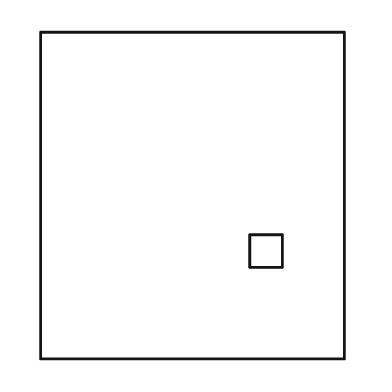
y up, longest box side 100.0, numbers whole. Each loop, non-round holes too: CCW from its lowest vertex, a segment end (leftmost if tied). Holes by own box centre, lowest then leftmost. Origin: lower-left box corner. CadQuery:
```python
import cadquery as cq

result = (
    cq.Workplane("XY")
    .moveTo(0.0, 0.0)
    .lineTo(93.0, 0.0)
    .lineTo(93.0, 100.0)
    .lineTo(0.0, 100.0)
    .close()
    .moveTo(64.0, 28.0)
    .lineTo(74.0, 28.0)
    .lineTo(74.0, 38.0)
    .lineTo(64.0, 38.0)
    .close()
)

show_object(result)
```